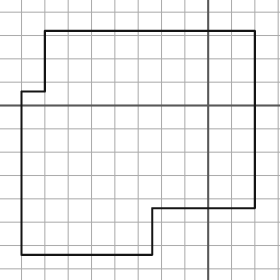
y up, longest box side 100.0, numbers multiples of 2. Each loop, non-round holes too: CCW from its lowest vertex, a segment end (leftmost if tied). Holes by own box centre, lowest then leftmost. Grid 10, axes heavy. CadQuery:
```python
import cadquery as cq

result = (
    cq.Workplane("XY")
    .moveTo(-80.0, -64.0)
    .lineTo(-24.0, -64.0)
    .lineTo(-24.0, -44.0)
    .lineTo(20.0, -44.0)
    .lineTo(20.0, 32.0)
    .lineTo(-70.0, 32.0)
    .lineTo(-70.0, 6.0)
    .lineTo(-80.0, 6.0)
    .close()
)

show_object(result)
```